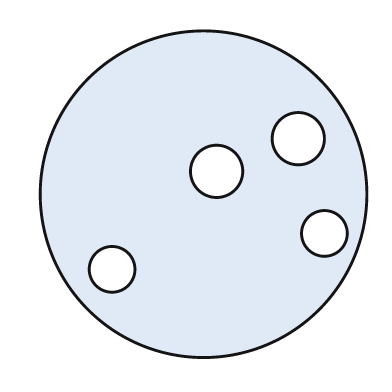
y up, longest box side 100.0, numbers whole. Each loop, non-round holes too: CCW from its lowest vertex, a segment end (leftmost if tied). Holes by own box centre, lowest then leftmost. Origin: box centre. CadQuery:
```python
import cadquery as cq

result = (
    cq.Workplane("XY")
    .moveTo(0.0, 0.0)
    .circle(50.0)
    .moveTo(-28.0, -23.0)
    .circle(7.0)
    .moveTo(37.0, -12.0)
    .circle(7.0)
    .moveTo(4.0, 7.0)
    .circle(8.0)
    .moveTo(29.0, 17.0)
    .circle(8.0)
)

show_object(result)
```